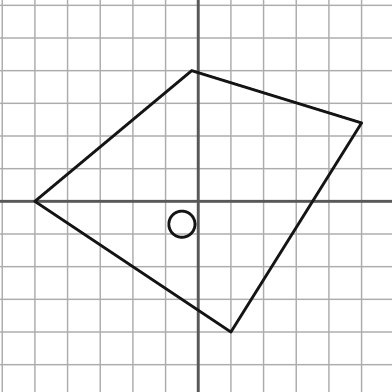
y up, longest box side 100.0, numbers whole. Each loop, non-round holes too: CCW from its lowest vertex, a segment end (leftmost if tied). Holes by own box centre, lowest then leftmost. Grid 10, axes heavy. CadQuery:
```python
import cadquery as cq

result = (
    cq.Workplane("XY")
    .moveTo(10.0, -40.0)
    .lineTo(50.0, 24.0)
    .lineTo(-2.0, 40.0)
    .lineTo(-50.0, 0.0)
    .close()
    .moveTo(-5.0, -7.0)
    .circle(4.0)
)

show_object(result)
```